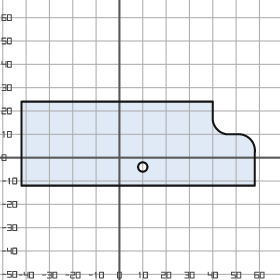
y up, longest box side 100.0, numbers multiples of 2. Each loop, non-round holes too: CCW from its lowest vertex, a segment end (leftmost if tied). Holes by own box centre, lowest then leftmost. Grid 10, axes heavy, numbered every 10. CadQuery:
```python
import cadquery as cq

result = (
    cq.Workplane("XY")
    .moveTo(-42.0, -12.0)
    .lineTo(58.0, -12.0)
    .lineTo(58.0, 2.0)
    .threePointArc((56.0, 8.0), (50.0, 10.0))
    .lineTo(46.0, 10.0)
    .threePointArc((42.0, 12.0), (40.0, 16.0))
    .lineTo(40.0, 24.0)
    .lineTo(-42.0, 24.0)
    .close()
    .moveTo(10.0, -4.0)
    .circle(2.0)
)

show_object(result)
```